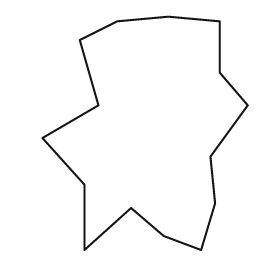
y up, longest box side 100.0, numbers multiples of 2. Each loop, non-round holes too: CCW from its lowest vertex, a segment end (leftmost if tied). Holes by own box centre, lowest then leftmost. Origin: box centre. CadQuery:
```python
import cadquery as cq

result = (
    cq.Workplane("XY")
    .moveTo(-26.0, -50.0)
    .lineTo(-6.0, -32.0)
    .lineTo(8.0, -44.0)
    .lineTo(24.0, -50.0)
    .lineTo(30.0, -30.0)
    .lineTo(28.0, -10.0)
    .lineTo(44.0, 12.0)
    .lineTo(32.0, 26.0)
    .lineTo(32.0, 48.0)
    .lineTo(10.0, 50.0)
    .lineTo(-12.0, 48.0)
    .lineTo(-28.0, 40.0)
    .lineTo(-20.0, 12.0)
    .lineTo(-44.0, -2.0)
    .lineTo(-26.0, -22.0)
    .close()
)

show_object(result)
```